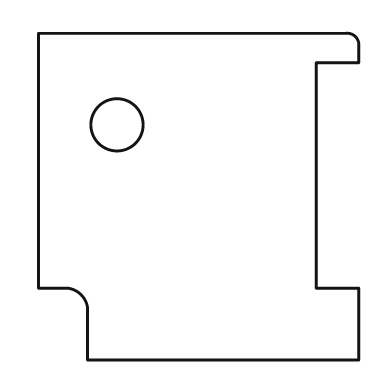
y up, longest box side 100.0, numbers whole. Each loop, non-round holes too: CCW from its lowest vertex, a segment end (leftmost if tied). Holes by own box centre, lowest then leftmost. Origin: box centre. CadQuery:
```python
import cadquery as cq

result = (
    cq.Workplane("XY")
    .moveTo(-34.0, -50.0)
    .lineTo(49.0, -50.0)
    .lineTo(49.0, -28.0)
    .lineTo(36.0, -28.0)
    .lineTo(36.0, 41.0)
    .lineTo(49.0, 41.0)
    .lineTo(49.0, 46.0)
    .threePointArc((48.0, 49.0), (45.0, 50.0))
    .lineTo(-49.0, 50.0)
    .lineTo(-49.0, -28.0)
    .lineTo(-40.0, -28.0)
    .threePointArc((-36.0, -30.0), (-34.0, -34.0))
    .close()
    .moveTo(-25.0, 22.0)
    .circle(8.0)
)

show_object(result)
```